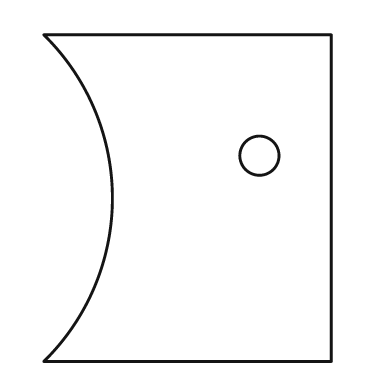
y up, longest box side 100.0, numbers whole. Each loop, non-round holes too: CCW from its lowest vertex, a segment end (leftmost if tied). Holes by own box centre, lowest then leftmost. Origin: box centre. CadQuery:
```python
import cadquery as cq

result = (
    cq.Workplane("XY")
    .moveTo(-44.0, -50.0)
    .lineTo(44.0, -50.0)
    .lineTo(44.0, 50.0)
    .lineTo(-44.0, 50.0)
    .threePointArc((-23.0, 0.0), (-44.0, -50.0))
    .close()
    .moveTo(22.0, 13.0)
    .circle(6.0)
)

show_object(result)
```